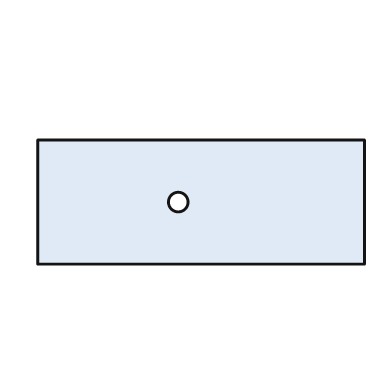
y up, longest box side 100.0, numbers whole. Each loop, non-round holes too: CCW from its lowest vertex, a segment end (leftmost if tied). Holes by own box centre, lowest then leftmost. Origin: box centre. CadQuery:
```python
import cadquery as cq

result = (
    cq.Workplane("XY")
    .moveTo(-50.0, -19.0)
    .lineTo(50.0, -19.0)
    .lineTo(50.0, 19.0)
    .lineTo(-50.0, 19.0)
    .close()
    .moveTo(-7.0, 0.0)
    .circle(3.0)
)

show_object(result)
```